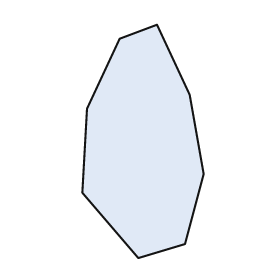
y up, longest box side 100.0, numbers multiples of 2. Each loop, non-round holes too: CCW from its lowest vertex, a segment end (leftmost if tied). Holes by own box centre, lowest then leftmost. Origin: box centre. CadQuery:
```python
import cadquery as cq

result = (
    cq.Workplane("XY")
    .moveTo(-2.0, -50.0)
    .lineTo(18.0, -44.0)
    .lineTo(26.0, -14.0)
    .lineTo(20.0, 20.0)
    .lineTo(6.0, 50.0)
    .lineTo(-10.0, 44.0)
    .lineTo(-24.0, 14.0)
    .lineTo(-26.0, -22.0)
    .close()
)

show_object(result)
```